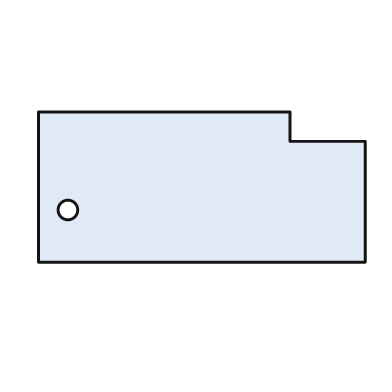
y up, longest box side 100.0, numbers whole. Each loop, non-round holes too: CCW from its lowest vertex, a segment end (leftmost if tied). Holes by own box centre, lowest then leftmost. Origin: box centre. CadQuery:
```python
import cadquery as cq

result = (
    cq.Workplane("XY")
    .moveTo(-50.0, -23.0)
    .lineTo(50.0, -23.0)
    .lineTo(50.0, 14.0)
    .lineTo(27.0, 14.0)
    .lineTo(27.0, 23.0)
    .lineTo(-50.0, 23.0)
    .close()
    .moveTo(-41.0, -7.0)
    .circle(3.0)
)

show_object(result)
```